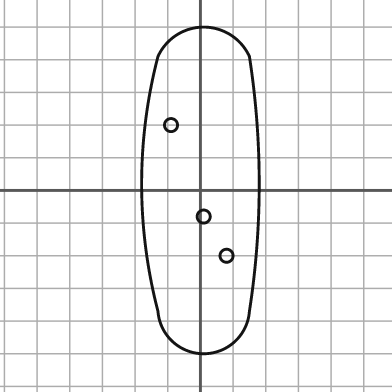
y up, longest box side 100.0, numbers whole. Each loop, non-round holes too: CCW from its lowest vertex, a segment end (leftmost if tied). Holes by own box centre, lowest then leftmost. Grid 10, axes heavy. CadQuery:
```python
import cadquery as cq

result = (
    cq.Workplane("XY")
    .moveTo(-13.0, -37.0)
    .threePointArc((1.0, -50.0), (15.0, -37.0))
    .threePointArc((18.0, 2.0), (15.0, 41.0))
    .threePointArc((1.0, 50.0), (-13.0, 41.0))
    .threePointArc((-18.0, 2.0), (-13.0, -37.0))
    .close()
    .moveTo(8.0, -20.0)
    .circle(2.0)
    .moveTo(1.0, -8.0)
    .circle(2.0)
    .moveTo(-9.0, 20.0)
    .circle(2.0)
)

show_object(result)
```